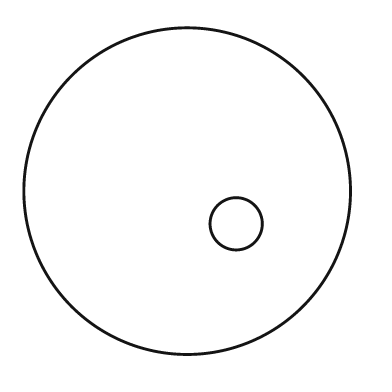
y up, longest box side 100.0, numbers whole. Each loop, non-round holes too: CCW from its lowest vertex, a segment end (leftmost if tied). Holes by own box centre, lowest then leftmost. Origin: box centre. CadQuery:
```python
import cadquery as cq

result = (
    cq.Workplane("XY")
    .moveTo(0.0, 0.0)
    .circle(50.0)
    .moveTo(15.0, -10.0)
    .circle(8.0)
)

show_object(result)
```